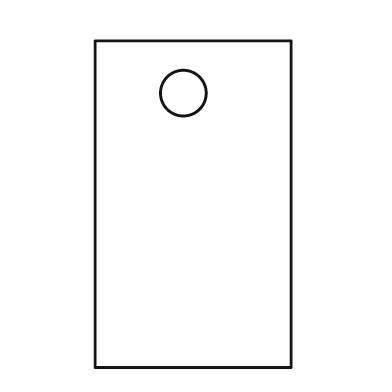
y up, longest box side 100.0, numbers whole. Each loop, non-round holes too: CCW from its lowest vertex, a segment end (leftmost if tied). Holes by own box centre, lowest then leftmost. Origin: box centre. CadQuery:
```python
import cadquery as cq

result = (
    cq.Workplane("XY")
    .moveTo(-30.0, -50.0)
    .lineTo(30.0, -50.0)
    .lineTo(30.0, 50.0)
    .lineTo(-30.0, 50.0)
    .close()
    .moveTo(-3.0, 34.0)
    .circle(7.0)
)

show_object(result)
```